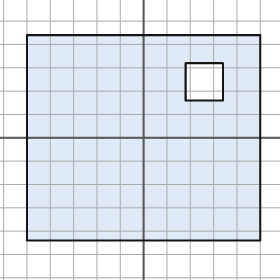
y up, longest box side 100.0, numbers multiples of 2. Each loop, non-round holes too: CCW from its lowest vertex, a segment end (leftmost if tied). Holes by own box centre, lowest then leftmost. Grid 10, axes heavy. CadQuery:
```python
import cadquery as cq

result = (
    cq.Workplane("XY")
    .moveTo(-50.0, -44.0)
    .lineTo(50.0, -44.0)
    .lineTo(50.0, 44.0)
    .lineTo(-50.0, 44.0)
    .close()
    .moveTo(18.0, 16.0)
    .lineTo(34.0, 16.0)
    .lineTo(34.0, 32.0)
    .lineTo(18.0, 32.0)
    .close()
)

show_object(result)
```